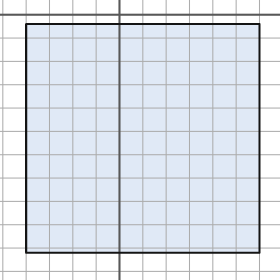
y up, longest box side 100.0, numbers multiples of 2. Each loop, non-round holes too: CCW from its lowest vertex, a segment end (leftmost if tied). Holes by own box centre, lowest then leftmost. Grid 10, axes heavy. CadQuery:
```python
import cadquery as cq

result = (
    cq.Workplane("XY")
    .moveTo(-40.0, -102.0)
    .lineTo(60.0, -102.0)
    .lineTo(60.0, -4.0)
    .lineTo(-40.0, -4.0)
    .close()
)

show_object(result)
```